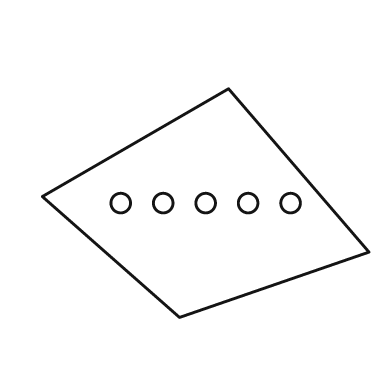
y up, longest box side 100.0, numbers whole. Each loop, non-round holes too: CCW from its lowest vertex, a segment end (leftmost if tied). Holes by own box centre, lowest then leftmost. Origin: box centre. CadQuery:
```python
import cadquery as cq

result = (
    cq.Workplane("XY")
    .moveTo(-8.0, -35.0)
    .lineTo(50.0, -15.0)
    .lineTo(7.0, 35.0)
    .lineTo(-50.0, 2.0)
    .close()
    .moveTo(-26.0, 0.0)
    .circle(3.0)
    .moveTo(-13.0, 0.0)
    .circle(3.0)
    .moveTo(0.0, 0.0)
    .circle(3.0)
    .moveTo(13.0, 0.0)
    .circle(3.0)
    .moveTo(26.0, 0.0)
    .circle(3.0)
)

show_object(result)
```